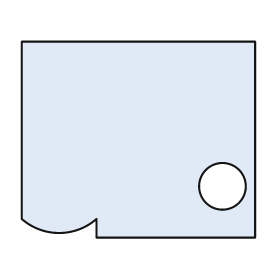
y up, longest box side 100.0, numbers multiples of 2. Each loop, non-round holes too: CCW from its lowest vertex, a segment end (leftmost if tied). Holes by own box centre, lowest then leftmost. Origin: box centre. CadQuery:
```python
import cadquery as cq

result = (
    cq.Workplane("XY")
    .moveTo(-18.0, -42.0)
    .lineTo(50.0, -42.0)
    .lineTo(50.0, 42.0)
    .lineTo(-50.0, 42.0)
    .lineTo(-50.0, -34.0)
    .threePointArc((-34.0, -40.0), (-18.0, -34.0))
    .close()
    .moveTo(36.0, -20.0)
    .circle(10.0)
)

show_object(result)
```